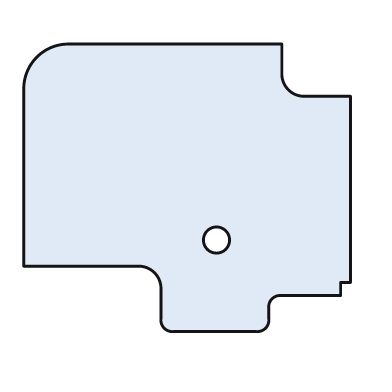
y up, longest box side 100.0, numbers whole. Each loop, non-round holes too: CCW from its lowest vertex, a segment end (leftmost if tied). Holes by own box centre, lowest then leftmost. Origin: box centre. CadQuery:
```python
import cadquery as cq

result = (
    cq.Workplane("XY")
    .moveTo(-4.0, -44.0)
    .lineTo(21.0, -44.0)
    .threePointArc((24.0, -43.0), (25.0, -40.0))
    .lineTo(25.0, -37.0)
    .threePointArc((26.0, -34.0), (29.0, -33.0))
    .lineTo(47.0, -33.0)
    .lineTo(47.0, -29.0)
    .lineTo(50.0, -29.0)
    .lineTo(50.0, 28.0)
    .lineTo(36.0, 28.0)
    .threePointArc((31.0, 30.0), (29.0, 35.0))
    .lineTo(29.0, 44.0)
    .lineTo(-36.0, 44.0)
    .threePointArc((-46.0, 40.0), (-50.0, 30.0))
    .lineTo(-50.0, -24.0)
    .lineTo(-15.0, -24.0)
    .threePointArc((-10.0, -26.0), (-8.0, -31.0))
    .lineTo(-8.0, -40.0)
    .threePointArc((-7.0, -43.0), (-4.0, -44.0))
    .close()
    .moveTo(9.0, -16.0)
    .circle(4.0)
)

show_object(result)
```